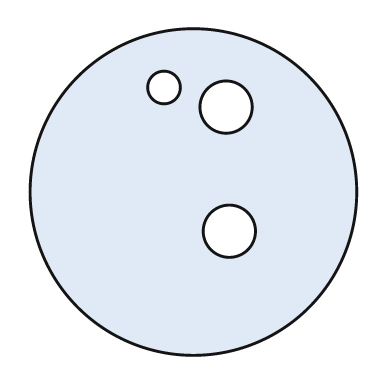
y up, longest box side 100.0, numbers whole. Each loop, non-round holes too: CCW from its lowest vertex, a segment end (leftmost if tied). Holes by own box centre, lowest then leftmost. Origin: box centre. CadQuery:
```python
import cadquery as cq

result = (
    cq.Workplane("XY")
    .moveTo(0.0, 0.0)
    .circle(50.0)
    .moveTo(11.0, -12.0)
    .circle(8.0)
    .moveTo(10.0, 26.0)
    .circle(8.0)
    .moveTo(-9.0, 32.0)
    .circle(5.0)
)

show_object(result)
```